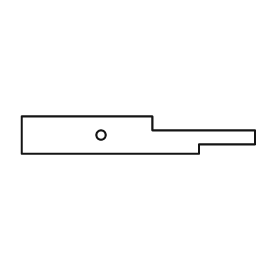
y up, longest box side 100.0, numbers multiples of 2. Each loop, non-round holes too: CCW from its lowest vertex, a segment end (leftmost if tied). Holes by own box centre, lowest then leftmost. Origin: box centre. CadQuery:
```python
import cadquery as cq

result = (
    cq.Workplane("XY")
    .moveTo(-50.0, -8.0)
    .lineTo(26.0, -8.0)
    .lineTo(26.0, -4.0)
    .lineTo(50.0, -4.0)
    .lineTo(50.0, 2.0)
    .lineTo(6.0, 2.0)
    .lineTo(6.0, 8.0)
    .lineTo(-50.0, 8.0)
    .close()
    .moveTo(-16.0, 0.0)
    .circle(2.0)
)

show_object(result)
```